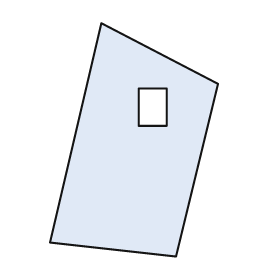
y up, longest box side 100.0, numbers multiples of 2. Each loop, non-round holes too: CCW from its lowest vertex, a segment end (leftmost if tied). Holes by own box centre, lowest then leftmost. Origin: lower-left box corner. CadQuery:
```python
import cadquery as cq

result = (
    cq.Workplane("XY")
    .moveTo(54.0, 0.0)
    .lineTo(72.0, 74.0)
    .lineTo(22.0, 100.0)
    .lineTo(0.0, 6.0)
    .close()
    .moveTo(38.0, 56.0)
    .lineTo(50.0, 56.0)
    .lineTo(50.0, 72.0)
    .lineTo(38.0, 72.0)
    .close()
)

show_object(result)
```